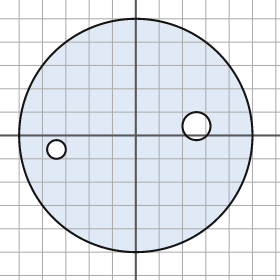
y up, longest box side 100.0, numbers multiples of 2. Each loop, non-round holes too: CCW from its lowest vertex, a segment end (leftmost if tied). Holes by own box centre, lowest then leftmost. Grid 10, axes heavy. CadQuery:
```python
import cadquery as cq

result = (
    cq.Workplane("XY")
    .moveTo(0.0, 0.0)
    .circle(50.0)
    .moveTo(-34.0, -6.0)
    .circle(4.0)
    .moveTo(26.0, 4.0)
    .circle(6.0)
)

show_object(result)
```